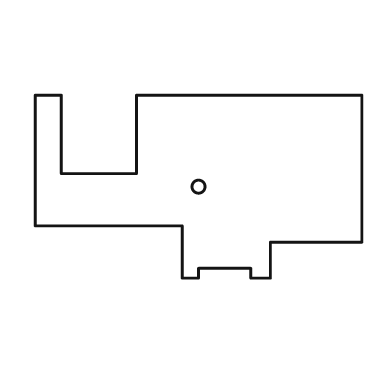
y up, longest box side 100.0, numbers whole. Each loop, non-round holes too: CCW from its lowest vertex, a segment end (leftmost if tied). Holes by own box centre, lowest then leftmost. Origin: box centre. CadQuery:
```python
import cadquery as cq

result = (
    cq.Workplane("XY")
    .moveTo(-5.0, -28.0)
    .lineTo(0.0, -28.0)
    .lineTo(0.0, -25.0)
    .lineTo(16.0, -25.0)
    .lineTo(16.0, -28.0)
    .lineTo(22.0, -28.0)
    .lineTo(22.0, -17.0)
    .lineTo(50.0, -17.0)
    .lineTo(50.0, 28.0)
    .lineTo(-19.0, 28.0)
    .lineTo(-19.0, 4.0)
    .lineTo(-42.0, 4.0)
    .lineTo(-42.0, 28.0)
    .lineTo(-50.0, 28.0)
    .lineTo(-50.0, -12.0)
    .lineTo(-5.0, -12.0)
    .close()
    .moveTo(0.0, 0.0)
    .circle(2.0)
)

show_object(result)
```